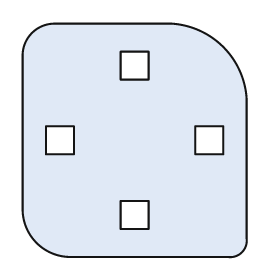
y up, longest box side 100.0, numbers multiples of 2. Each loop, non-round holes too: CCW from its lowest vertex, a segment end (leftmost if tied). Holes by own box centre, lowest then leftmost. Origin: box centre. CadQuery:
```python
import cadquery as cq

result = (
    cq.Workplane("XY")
    .moveTo(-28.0, -50.0)
    .lineTo(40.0, -50.0)
    .threePointArc((46.0, -48.0), (48.0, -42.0))
    .lineTo(48.0, 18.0)
    .threePointArc((38.0, 40.0), (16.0, 50.0))
    .lineTo(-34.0, 50.0)
    .threePointArc((-44.0, 46.0), (-48.0, 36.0))
    .lineTo(-48.0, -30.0)
    .threePointArc((-42.0, -44.0), (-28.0, -50.0))
    .close()
    .moveTo(-6.0, -38.0)
    .lineTo(6.0, -38.0)
    .lineTo(6.0, -26.0)
    .lineTo(-6.0, -26.0)
    .close()
    .moveTo(-38.0, -6.0)
    .lineTo(-26.0, -6.0)
    .lineTo(-26.0, 6.0)
    .lineTo(-38.0, 6.0)
    .close()
    .moveTo(26.0, -6.0)
    .lineTo(38.0, -6.0)
    .lineTo(38.0, 6.0)
    .lineTo(26.0, 6.0)
    .close()
    .moveTo(-6.0, 26.0)
    .lineTo(6.0, 26.0)
    .lineTo(6.0, 38.0)
    .lineTo(-6.0, 38.0)
    .close()
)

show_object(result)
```